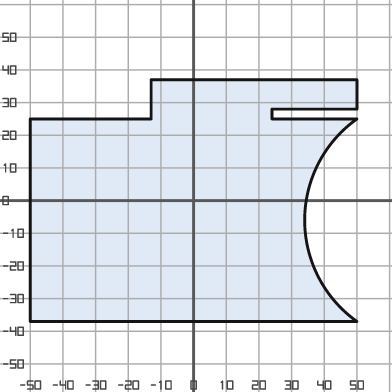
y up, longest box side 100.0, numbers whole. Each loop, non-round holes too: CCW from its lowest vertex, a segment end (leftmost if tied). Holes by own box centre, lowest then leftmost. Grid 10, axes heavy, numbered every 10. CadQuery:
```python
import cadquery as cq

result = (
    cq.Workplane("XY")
    .moveTo(-50.0, -37.0)
    .lineTo(50.0, -37.0)
    .threePointArc((34.0, -6.0), (50.0, 25.0))
    .lineTo(24.0, 25.0)
    .lineTo(24.0, 28.0)
    .lineTo(50.0, 28.0)
    .lineTo(50.0, 37.0)
    .lineTo(-13.0, 37.0)
    .lineTo(-13.0, 25.0)
    .lineTo(-50.0, 25.0)
    .close()
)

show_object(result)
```